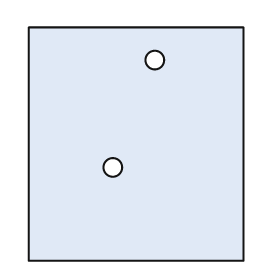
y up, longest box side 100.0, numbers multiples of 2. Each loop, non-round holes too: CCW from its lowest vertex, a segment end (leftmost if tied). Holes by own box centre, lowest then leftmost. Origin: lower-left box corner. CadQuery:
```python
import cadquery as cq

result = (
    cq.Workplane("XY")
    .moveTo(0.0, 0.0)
    .lineTo(92.0, 0.0)
    .lineTo(92.0, 100.0)
    .lineTo(0.0, 100.0)
    .close()
    .moveTo(36.0, 40.0)
    .circle(4.0)
    .moveTo(54.0, 86.0)
    .circle(4.0)
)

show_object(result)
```